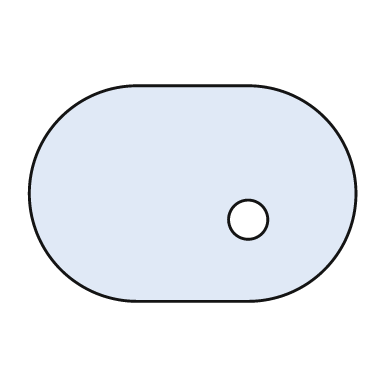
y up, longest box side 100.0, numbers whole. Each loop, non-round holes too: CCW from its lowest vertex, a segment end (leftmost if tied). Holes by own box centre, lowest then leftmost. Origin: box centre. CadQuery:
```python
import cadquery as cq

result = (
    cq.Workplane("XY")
    .moveTo(-17.0, -33.0)
    .lineTo(17.0, -33.0)
    .threePointArc((50.0, 0.0), (17.0, 33.0))
    .lineTo(-17.0, 33.0)
    .threePointArc((-50.0, 0.0), (-17.0, -33.0))
    .close()
    .moveTo(17.0, -8.0)
    .circle(6.0)
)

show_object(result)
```